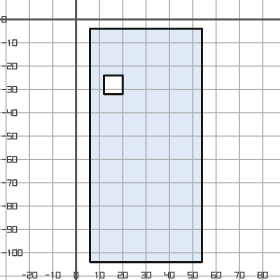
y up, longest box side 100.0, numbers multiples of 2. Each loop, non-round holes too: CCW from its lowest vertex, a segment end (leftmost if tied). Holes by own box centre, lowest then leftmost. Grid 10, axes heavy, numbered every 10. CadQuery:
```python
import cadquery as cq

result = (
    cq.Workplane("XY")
    .moveTo(6.0, -104.0)
    .lineTo(54.0, -104.0)
    .lineTo(54.0, -4.0)
    .lineTo(6.0, -4.0)
    .close()
    .moveTo(12.0, -32.0)
    .lineTo(20.0, -32.0)
    .lineTo(20.0, -24.0)
    .lineTo(12.0, -24.0)
    .close()
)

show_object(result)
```